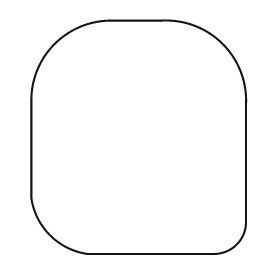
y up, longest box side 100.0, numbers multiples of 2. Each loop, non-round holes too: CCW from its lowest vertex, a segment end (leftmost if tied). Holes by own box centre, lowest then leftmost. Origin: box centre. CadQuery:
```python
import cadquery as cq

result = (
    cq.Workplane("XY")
    .moveTo(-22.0, -50.0)
    .lineTo(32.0, -50.0)
    .threePointArc((42.0, -46.0), (46.0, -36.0))
    .lineTo(46.0, 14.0)
    .threePointArc((36.0, 40.0), (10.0, 50.0))
    .lineTo(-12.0, 50.0)
    .threePointArc((-36.0, 40.0), (-46.0, 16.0))
    .lineTo(-46.0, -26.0)
    .threePointArc((-38.0, -42.0), (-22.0, -50.0))
    .close()
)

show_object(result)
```